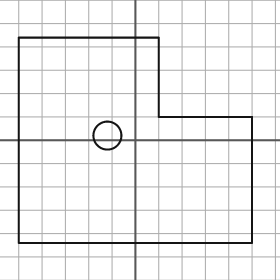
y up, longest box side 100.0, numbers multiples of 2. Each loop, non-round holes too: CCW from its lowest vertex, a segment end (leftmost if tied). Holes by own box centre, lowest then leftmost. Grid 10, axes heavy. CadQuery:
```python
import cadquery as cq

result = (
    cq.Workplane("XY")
    .moveTo(-50.0, -44.0)
    .lineTo(50.0, -44.0)
    .lineTo(50.0, 10.0)
    .lineTo(10.0, 10.0)
    .lineTo(10.0, 44.0)
    .lineTo(-50.0, 44.0)
    .close()
    .moveTo(-12.0, 2.0)
    .circle(6.0)
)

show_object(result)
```